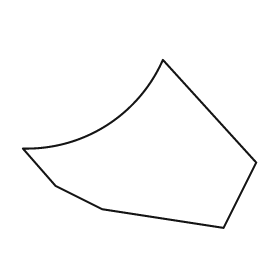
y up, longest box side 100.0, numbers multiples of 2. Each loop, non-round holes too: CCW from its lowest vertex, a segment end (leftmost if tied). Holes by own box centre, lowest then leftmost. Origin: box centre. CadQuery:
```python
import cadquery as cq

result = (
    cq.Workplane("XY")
    .moveTo(36.0, -36.0)
    .lineTo(50.0, -8.0)
    .lineTo(10.0, 36.0)
    .threePointArc((-14.0, 8.0), (-50.0, -2.0))
    .lineTo(-36.0, -18.0)
    .lineTo(-16.0, -28.0)
    .close()
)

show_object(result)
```